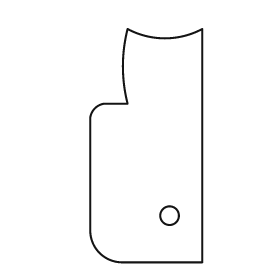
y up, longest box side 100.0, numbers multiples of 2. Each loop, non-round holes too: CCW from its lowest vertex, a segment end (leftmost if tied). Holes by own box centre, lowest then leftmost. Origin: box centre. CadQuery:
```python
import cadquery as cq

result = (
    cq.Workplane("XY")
    .moveTo(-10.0, -50.0)
    .lineTo(24.0, -50.0)
    .lineTo(24.0, 50.0)
    .threePointArc((8.0, 46.0), (-8.0, 50.0))
    .threePointArc((-10.0, 34.0), (-8.0, 18.0))
    .lineTo(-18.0, 18.0)
    .threePointArc((-22.0, 16.0), (-24.0, 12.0))
    .lineTo(-24.0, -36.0)
    .threePointArc((-20.0, -46.0), (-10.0, -50.0))
    .close()
    .moveTo(10.0, -30.0)
    .circle(4.0)
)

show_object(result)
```